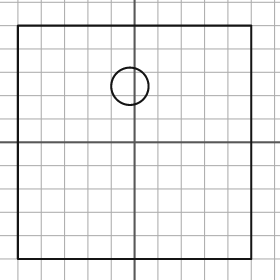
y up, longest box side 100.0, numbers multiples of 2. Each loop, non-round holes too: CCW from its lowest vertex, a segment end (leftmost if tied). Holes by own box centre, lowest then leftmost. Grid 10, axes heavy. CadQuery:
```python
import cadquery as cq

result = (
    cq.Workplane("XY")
    .moveTo(-50.0, -50.0)
    .lineTo(50.0, -50.0)
    .lineTo(50.0, 50.0)
    .lineTo(-50.0, 50.0)
    .close()
    .moveTo(-2.0, 24.0)
    .circle(8.0)
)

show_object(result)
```